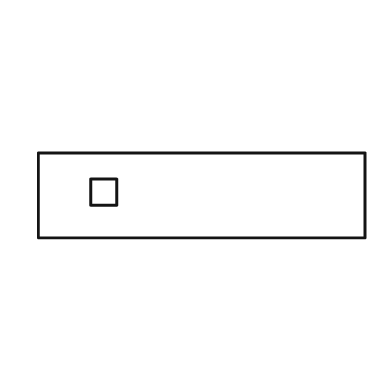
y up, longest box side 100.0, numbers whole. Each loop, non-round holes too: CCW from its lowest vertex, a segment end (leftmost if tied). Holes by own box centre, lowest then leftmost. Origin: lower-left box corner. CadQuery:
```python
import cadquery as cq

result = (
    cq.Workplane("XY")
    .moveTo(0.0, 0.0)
    .lineTo(100.0, 0.0)
    .lineTo(100.0, 26.0)
    .lineTo(0.0, 26.0)
    .close()
    .moveTo(16.0, 10.0)
    .lineTo(24.0, 10.0)
    .lineTo(24.0, 18.0)
    .lineTo(16.0, 18.0)
    .close()
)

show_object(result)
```